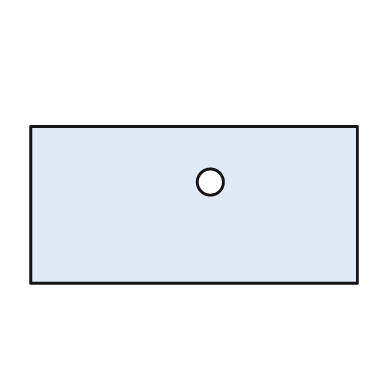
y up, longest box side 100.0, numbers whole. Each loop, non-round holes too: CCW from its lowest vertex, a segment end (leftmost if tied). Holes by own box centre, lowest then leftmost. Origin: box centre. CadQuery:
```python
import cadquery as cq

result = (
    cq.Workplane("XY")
    .moveTo(-50.0, -24.0)
    .lineTo(50.0, -24.0)
    .lineTo(50.0, 24.0)
    .lineTo(-50.0, 24.0)
    .close()
    .moveTo(5.0, 7.0)
    .circle(4.0)
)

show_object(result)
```